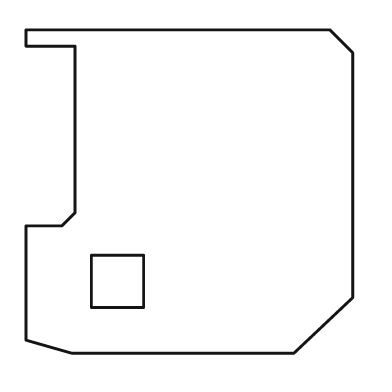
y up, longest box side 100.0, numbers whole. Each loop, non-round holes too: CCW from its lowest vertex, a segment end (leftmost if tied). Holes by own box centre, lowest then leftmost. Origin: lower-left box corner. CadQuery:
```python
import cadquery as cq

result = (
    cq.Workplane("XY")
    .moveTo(14.0, 0.0)
    .lineTo(82.0, 0.0)
    .lineTo(100.0, 17.0)
    .lineTo(100.0, 92.0)
    .lineTo(93.0, 99.0)
    .lineTo(0.0, 99.0)
    .lineTo(0.0, 94.0)
    .lineTo(15.0, 94.0)
    .lineTo(15.0, 43.0)
    .lineTo(11.0, 39.0)
    .lineTo(0.0, 39.0)
    .lineTo(0.0, 4.0)
    .close()
    .moveTo(20.0, 14.0)
    .lineTo(36.0, 14.0)
    .lineTo(36.0, 30.0)
    .lineTo(20.0, 30.0)
    .close()
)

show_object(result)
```